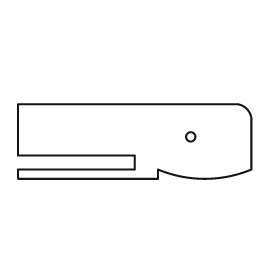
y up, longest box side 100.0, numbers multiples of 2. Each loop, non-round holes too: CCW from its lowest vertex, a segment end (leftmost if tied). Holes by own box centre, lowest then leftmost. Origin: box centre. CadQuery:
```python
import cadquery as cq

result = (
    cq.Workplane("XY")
    .moveTo(-50.0, -16.0)
    .lineTo(10.0, -16.0)
    .lineTo(10.0, -12.0)
    .threePointArc((30.0, -16.0), (50.0, -12.0))
    .lineTo(50.0, 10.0)
    .threePointArc((48.0, 14.0), (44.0, 16.0))
    .lineTo(-50.0, 16.0)
    .lineTo(-50.0, -6.0)
    .lineTo(0.0, -6.0)
    .lineTo(0.0, -12.0)
    .lineTo(-50.0, -12.0)
    .close()
    .moveTo(24.0, 2.0)
    .circle(2.0)
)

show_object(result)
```